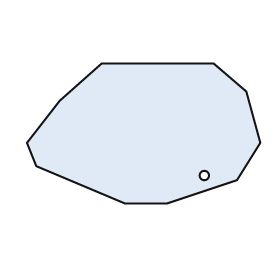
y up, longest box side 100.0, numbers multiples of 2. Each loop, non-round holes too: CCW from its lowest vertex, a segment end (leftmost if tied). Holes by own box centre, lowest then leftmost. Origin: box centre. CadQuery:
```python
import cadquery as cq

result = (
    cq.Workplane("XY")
    .moveTo(-8.0, -30.0)
    .lineTo(10.0, -30.0)
    .lineTo(40.0, -20.0)
    .lineTo(50.0, -4.0)
    .lineTo(44.0, 18.0)
    .lineTo(30.0, 30.0)
    .lineTo(-18.0, 30.0)
    .lineTo(-36.0, 14.0)
    .lineTo(-50.0, -4.0)
    .lineTo(-46.0, -14.0)
    .close()
    .moveTo(26.0, -18.0)
    .circle(2.0)
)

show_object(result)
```